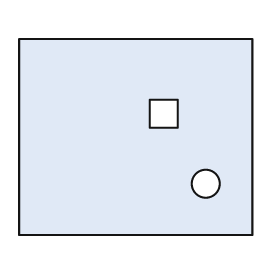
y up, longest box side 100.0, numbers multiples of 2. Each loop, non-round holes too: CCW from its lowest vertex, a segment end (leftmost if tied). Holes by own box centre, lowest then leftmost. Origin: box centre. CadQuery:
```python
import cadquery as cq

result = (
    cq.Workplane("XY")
    .moveTo(-50.0, -42.0)
    .lineTo(50.0, -42.0)
    .lineTo(50.0, 42.0)
    .lineTo(-50.0, 42.0)
    .close()
    .moveTo(30.0, -20.0)
    .circle(6.0)
    .moveTo(6.0, 4.0)
    .lineTo(18.0, 4.0)
    .lineTo(18.0, 16.0)
    .lineTo(6.0, 16.0)
    .close()
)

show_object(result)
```